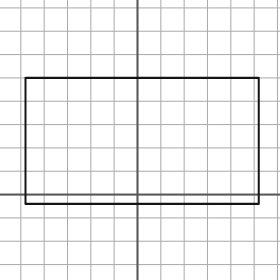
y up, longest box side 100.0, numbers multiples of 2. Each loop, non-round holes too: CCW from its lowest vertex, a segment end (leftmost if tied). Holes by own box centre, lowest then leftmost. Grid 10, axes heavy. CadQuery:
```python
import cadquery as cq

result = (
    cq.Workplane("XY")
    .moveTo(-48.0, -4.0)
    .lineTo(52.0, -4.0)
    .lineTo(52.0, 50.0)
    .lineTo(-48.0, 50.0)
    .close()
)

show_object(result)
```